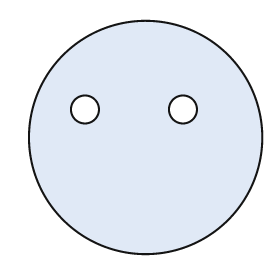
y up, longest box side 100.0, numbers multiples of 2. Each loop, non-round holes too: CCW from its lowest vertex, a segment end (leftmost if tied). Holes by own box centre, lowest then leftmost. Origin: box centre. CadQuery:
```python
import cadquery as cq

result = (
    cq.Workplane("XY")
    .moveTo(0.0, 0.0)
    .circle(50.0)
    .moveTo(-26.0, 12.0)
    .circle(6.0)
    .moveTo(16.0, 12.0)
    .circle(6.0)
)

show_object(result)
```